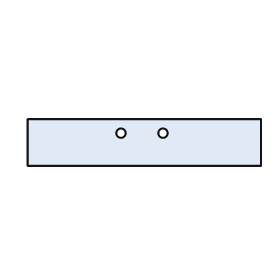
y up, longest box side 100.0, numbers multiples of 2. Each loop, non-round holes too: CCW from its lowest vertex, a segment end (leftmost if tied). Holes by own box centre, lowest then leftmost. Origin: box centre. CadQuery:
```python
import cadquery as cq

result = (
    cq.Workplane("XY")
    .moveTo(-50.0, -10.0)
    .lineTo(50.0, -10.0)
    .lineTo(50.0, 10.0)
    .lineTo(-50.0, 10.0)
    .close()
    .moveTo(-10.0, 4.0)
    .circle(2.0)
    .moveTo(8.0, 4.0)
    .circle(2.0)
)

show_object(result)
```